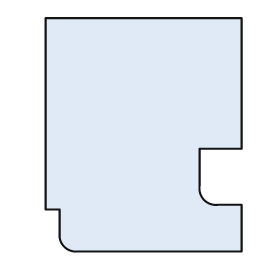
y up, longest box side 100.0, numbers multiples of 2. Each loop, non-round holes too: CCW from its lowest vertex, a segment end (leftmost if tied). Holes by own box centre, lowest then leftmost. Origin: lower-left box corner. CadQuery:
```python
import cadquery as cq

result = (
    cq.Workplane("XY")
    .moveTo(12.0, 0.0)
    .lineTo(84.0, 0.0)
    .lineTo(84.0, 20.0)
    .lineTo(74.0, 20.0)
    .threePointArc((68.0, 22.0), (66.0, 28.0))
    .lineTo(66.0, 44.0)
    .lineTo(84.0, 44.0)
    .lineTo(84.0, 100.0)
    .lineTo(0.0, 100.0)
    .lineTo(0.0, 18.0)
    .lineTo(6.0, 18.0)
    .lineTo(6.0, 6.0)
    .threePointArc((8.0, 2.0), (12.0, 0.0))
    .close()
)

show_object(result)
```